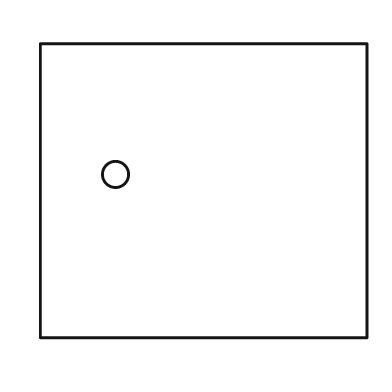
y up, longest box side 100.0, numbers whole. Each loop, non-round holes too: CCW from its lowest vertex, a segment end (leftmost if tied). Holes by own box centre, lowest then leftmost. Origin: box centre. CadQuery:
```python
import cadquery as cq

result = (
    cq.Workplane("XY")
    .moveTo(-50.0, -45.0)
    .lineTo(50.0, -45.0)
    .lineTo(50.0, 45.0)
    .lineTo(-50.0, 45.0)
    .close()
    .moveTo(-27.0, 5.0)
    .circle(4.0)
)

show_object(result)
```